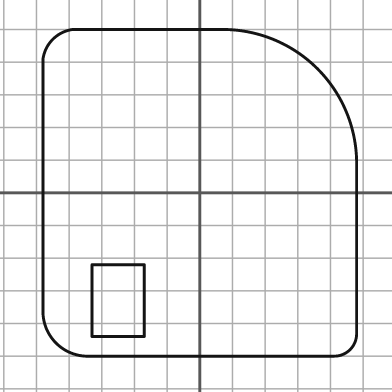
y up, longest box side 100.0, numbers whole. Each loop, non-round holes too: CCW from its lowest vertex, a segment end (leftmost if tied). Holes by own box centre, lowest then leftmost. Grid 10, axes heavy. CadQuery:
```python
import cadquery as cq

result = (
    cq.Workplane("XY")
    .moveTo(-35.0, -50.0)
    .lineTo(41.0, -50.0)
    .threePointArc((46.0, -48.0), (48.0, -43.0))
    .lineTo(48.0, 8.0)
    .threePointArc((36.0, 38.0), (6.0, 50.0))
    .lineTo(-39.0, 50.0)
    .threePointArc((-45.0, 47.0), (-48.0, 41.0))
    .lineTo(-48.0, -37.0)
    .threePointArc((-44.0, -46.0), (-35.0, -50.0))
    .close()
    .moveTo(-33.0, -44.0)
    .lineTo(-17.0, -44.0)
    .lineTo(-17.0, -22.0)
    .lineTo(-33.0, -22.0)
    .close()
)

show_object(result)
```